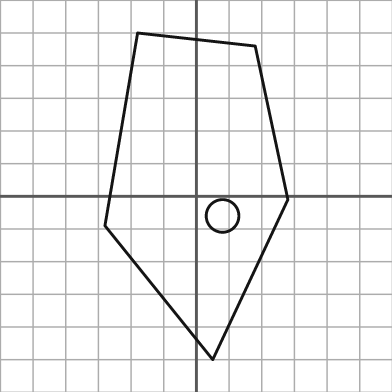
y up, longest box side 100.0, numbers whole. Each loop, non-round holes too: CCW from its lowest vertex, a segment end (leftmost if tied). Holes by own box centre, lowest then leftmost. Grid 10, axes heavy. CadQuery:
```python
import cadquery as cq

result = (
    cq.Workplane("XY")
    .moveTo(5.0, -50.0)
    .lineTo(28.0, -1.0)
    .lineTo(18.0, 46.0)
    .lineTo(-18.0, 50.0)
    .lineTo(-28.0, -9.0)
    .close()
    .moveTo(8.0, -6.0)
    .circle(5.0)
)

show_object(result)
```